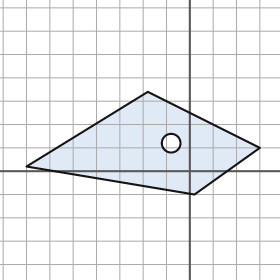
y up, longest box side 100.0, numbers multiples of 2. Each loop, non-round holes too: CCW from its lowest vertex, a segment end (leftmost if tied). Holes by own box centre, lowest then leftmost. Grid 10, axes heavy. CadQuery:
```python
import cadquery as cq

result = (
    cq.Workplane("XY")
    .moveTo(2.0, -10.0)
    .lineTo(30.0, 10.0)
    .lineTo(-18.0, 34.0)
    .lineTo(-70.0, 2.0)
    .close()
    .moveTo(-8.0, 12.0)
    .circle(4.0)
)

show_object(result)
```